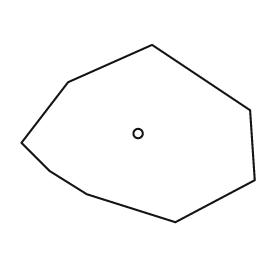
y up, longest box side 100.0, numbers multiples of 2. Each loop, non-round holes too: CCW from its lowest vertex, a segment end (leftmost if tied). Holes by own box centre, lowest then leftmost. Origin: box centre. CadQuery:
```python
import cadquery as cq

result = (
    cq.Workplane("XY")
    .moveTo(16.0, -38.0)
    .lineTo(50.0, -20.0)
    .lineTo(48.0, 10.0)
    .lineTo(6.0, 38.0)
    .lineTo(-30.0, 22.0)
    .lineTo(-50.0, -4.0)
    .lineTo(-38.0, -16.0)
    .lineTo(-22.0, -26.0)
    .close()
    .moveTo(0.0, 0.0)
    .circle(2.0)
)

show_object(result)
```